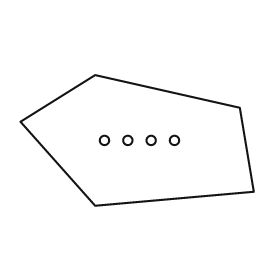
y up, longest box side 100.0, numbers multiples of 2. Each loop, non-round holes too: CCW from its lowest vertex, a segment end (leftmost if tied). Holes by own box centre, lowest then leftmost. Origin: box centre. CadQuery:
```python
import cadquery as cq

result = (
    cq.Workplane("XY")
    .moveTo(-18.0, -28.0)
    .lineTo(50.0, -22.0)
    .lineTo(44.0, 14.0)
    .lineTo(-18.0, 28.0)
    .lineTo(-50.0, 8.0)
    .close()
    .moveTo(-14.0, 0.0)
    .circle(2.0)
    .moveTo(-4.0, 0.0)
    .circle(2.0)
    .moveTo(6.0, 0.0)
    .circle(2.0)
    .moveTo(16.0, 0.0)
    .circle(2.0)
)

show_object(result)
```